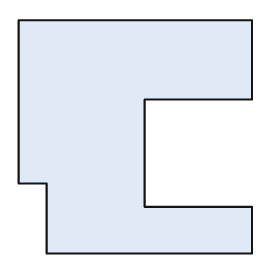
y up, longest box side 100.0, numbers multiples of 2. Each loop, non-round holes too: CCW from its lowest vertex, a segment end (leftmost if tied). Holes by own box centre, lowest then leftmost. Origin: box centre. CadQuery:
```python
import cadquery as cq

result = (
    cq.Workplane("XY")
    .moveTo(-38.0, -50.0)
    .lineTo(50.0, -50.0)
    .lineTo(50.0, -30.0)
    .lineTo(4.0, -30.0)
    .lineTo(4.0, 16.0)
    .lineTo(50.0, 16.0)
    .lineTo(50.0, 50.0)
    .lineTo(-50.0, 50.0)
    .lineTo(-50.0, -20.0)
    .lineTo(-38.0, -20.0)
    .close()
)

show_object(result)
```